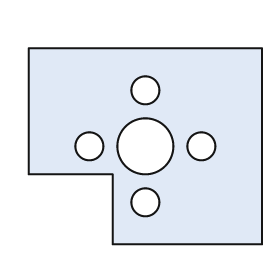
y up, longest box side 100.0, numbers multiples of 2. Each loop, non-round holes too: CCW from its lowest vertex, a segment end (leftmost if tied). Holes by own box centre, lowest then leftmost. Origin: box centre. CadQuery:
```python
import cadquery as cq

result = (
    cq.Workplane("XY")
    .moveTo(-14.0, -42.0)
    .lineTo(50.0, -42.0)
    .lineTo(50.0, 42.0)
    .lineTo(-50.0, 42.0)
    .lineTo(-50.0, -12.0)
    .lineTo(-14.0, -12.0)
    .close()
    .moveTo(0.0, -24.0)
    .circle(6.0)
    .moveTo(-24.0, 0.0)
    .circle(6.0)
    .moveTo(0.0, 0.0)
    .circle(12.0)
    .moveTo(24.0, 0.0)
    .circle(6.0)
    .moveTo(0.0, 24.0)
    .circle(6.0)
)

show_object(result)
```